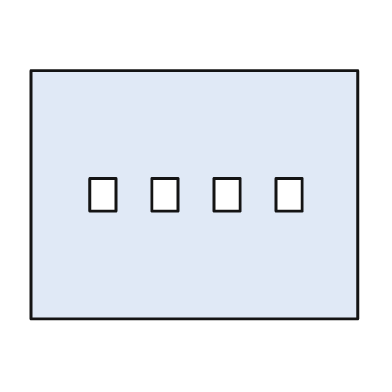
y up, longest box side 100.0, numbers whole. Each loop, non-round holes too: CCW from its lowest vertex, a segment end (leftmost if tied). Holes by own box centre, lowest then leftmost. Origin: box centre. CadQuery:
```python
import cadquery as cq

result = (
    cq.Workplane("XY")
    .moveTo(-50.0, -38.0)
    .lineTo(50.0, -38.0)
    .lineTo(50.0, 38.0)
    .lineTo(-50.0, 38.0)
    .close()
    .moveTo(-32.0, -5.0)
    .lineTo(-24.0, -5.0)
    .lineTo(-24.0, 5.0)
    .lineTo(-32.0, 5.0)
    .close()
    .moveTo(-13.0, -5.0)
    .lineTo(-5.0, -5.0)
    .lineTo(-5.0, 5.0)
    .lineTo(-13.0, 5.0)
    .close()
    .moveTo(6.0, -5.0)
    .lineTo(14.0, -5.0)
    .lineTo(14.0, 5.0)
    .lineTo(6.0, 5.0)
    .close()
    .moveTo(25.0, -5.0)
    .lineTo(33.0, -5.0)
    .lineTo(33.0, 5.0)
    .lineTo(25.0, 5.0)
    .close()
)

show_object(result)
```